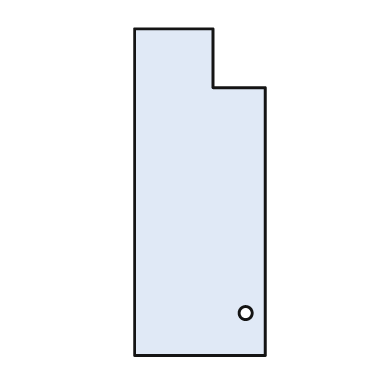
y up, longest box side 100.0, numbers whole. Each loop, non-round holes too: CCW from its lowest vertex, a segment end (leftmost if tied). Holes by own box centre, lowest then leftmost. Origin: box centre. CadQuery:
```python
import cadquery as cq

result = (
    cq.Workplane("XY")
    .moveTo(-20.0, -50.0)
    .lineTo(20.0, -50.0)
    .lineTo(20.0, 32.0)
    .lineTo(4.0, 32.0)
    .lineTo(4.0, 50.0)
    .lineTo(-20.0, 50.0)
    .close()
    .moveTo(14.0, -37.0)
    .circle(2.0)
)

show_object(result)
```